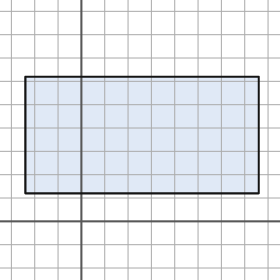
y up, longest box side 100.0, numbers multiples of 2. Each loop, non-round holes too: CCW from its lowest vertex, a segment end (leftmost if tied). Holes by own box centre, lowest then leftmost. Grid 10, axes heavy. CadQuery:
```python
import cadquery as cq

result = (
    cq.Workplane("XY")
    .moveTo(-24.0, 12.0)
    .lineTo(76.0, 12.0)
    .lineTo(76.0, 62.0)
    .lineTo(-24.0, 62.0)
    .close()
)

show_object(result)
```